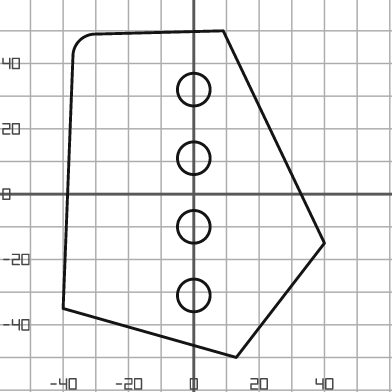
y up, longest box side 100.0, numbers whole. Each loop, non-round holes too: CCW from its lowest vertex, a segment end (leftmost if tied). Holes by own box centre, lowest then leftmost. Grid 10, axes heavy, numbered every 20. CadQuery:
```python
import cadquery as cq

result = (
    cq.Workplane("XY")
    .moveTo(13.0, -50.0)
    .lineTo(40.0, -15.0)
    .lineTo(9.0, 50.0)
    .lineTo(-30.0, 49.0)
    .threePointArc((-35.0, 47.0), (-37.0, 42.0))
    .lineTo(-40.0, -35.0)
    .close()
    .moveTo(0.0, -31.0)
    .circle(5.0)
    .moveTo(0.0, -10.0)
    .circle(5.0)
    .moveTo(0.0, 11.0)
    .circle(5.0)
    .moveTo(0.0, 32.0)
    .circle(5.0)
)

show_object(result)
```